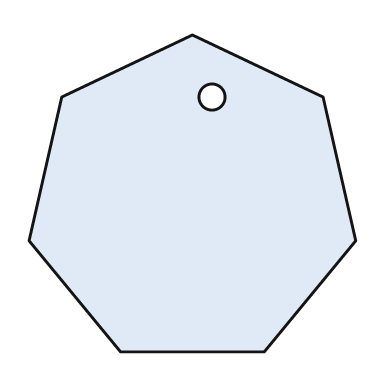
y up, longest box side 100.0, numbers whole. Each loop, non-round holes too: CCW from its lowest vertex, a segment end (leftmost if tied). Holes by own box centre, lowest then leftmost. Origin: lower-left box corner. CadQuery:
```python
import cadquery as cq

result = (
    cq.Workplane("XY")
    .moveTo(28.0, 0.0)
    .lineTo(72.0, 0.0)
    .lineTo(100.0, 34.0)
    .lineTo(90.0, 78.0)
    .lineTo(50.0, 97.0)
    .lineTo(10.0, 78.0)
    .lineTo(0.0, 34.0)
    .close()
    .moveTo(56.0, 78.0)
    .circle(4.0)
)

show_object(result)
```